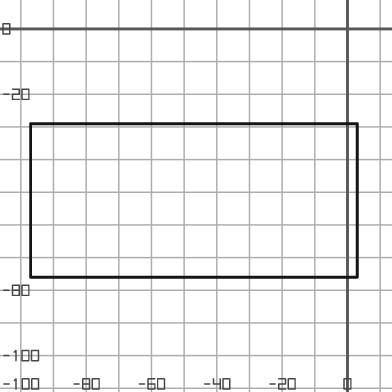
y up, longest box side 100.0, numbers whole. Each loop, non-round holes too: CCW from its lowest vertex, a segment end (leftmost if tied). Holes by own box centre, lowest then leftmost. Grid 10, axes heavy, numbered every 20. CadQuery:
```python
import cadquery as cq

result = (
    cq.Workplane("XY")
    .moveTo(-97.0, -76.0)
    .lineTo(3.0, -76.0)
    .lineTo(3.0, -29.0)
    .lineTo(-97.0, -29.0)
    .close()
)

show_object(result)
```